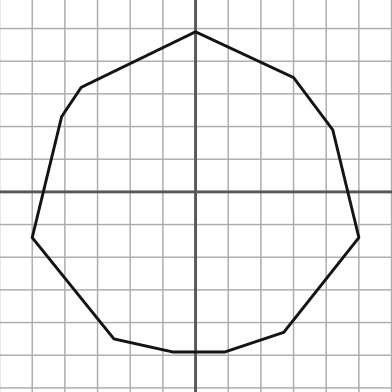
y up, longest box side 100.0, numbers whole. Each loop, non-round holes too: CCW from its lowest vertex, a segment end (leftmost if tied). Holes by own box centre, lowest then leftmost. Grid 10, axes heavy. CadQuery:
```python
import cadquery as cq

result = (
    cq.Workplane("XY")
    .moveTo(-7.0, -49.0)
    .lineTo(9.0, -49.0)
    .lineTo(27.0, -43.0)
    .lineTo(50.0, -14.0)
    .lineTo(42.0, 19.0)
    .lineTo(30.0, 35.0)
    .lineTo(0.0, 49.0)
    .lineTo(-35.0, 32.0)
    .lineTo(-41.0, 23.0)
    .lineTo(-50.0, -14.0)
    .lineTo(-25.0, -45.0)
    .close()
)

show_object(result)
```